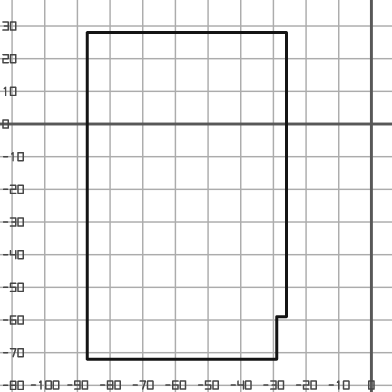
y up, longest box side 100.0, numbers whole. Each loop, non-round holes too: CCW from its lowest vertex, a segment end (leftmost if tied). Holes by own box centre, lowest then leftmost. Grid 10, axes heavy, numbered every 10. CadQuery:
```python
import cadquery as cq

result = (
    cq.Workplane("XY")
    .moveTo(-87.0, -72.0)
    .lineTo(-29.0, -72.0)
    .lineTo(-29.0, -59.0)
    .lineTo(-26.0, -59.0)
    .lineTo(-26.0, 28.0)
    .lineTo(-87.0, 28.0)
    .close()
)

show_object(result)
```